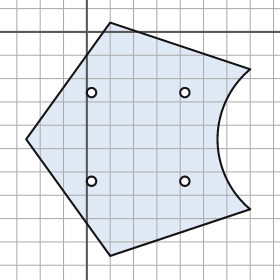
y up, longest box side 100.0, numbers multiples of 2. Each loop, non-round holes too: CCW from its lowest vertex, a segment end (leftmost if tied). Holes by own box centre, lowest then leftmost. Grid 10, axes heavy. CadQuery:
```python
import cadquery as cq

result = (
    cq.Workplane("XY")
    .moveTo(10.0, -96.0)
    .lineTo(70.0, -76.0)
    .threePointArc((56.0, -46.0), (70.0, -16.0))
    .lineTo(10.0, 4.0)
    .lineTo(-26.0, -46.0)
    .close()
    .moveTo(2.0, -64.0)
    .circle(2.0)
    .moveTo(42.0, -64.0)
    .circle(2.0)
    .moveTo(2.0, -26.0)
    .circle(2.0)
    .moveTo(42.0, -26.0)
    .circle(2.0)
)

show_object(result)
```